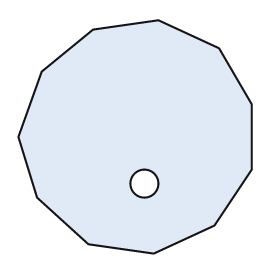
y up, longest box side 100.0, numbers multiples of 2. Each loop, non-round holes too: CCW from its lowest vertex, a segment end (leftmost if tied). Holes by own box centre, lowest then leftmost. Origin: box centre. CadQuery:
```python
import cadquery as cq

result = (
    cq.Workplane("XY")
    .moveTo(8.0, -50.0)
    .lineTo(34.0, -38.0)
    .lineTo(50.0, -14.0)
    .lineTo(50.0, 14.0)
    .lineTo(36.0, 38.0)
    .lineTo(10.0, 50.0)
    .lineTo(-18.0, 46.0)
    .lineTo(-40.0, 28.0)
    .lineTo(-50.0, 0.0)
    .lineTo(-42.0, -26.0)
    .lineTo(-20.0, -46.0)
    .close()
    .moveTo(4.0, -20.0)
    .circle(6.0)
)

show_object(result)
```